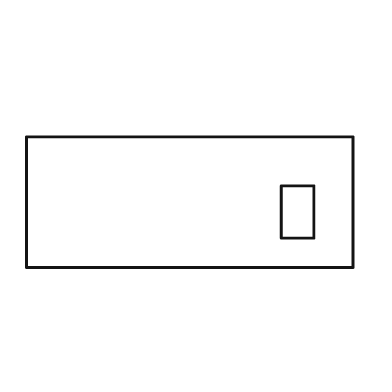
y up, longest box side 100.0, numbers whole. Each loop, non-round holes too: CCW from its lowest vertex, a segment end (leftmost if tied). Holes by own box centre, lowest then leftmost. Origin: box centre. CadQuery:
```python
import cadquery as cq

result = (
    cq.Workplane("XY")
    .moveTo(-50.0, -20.0)
    .lineTo(50.0, -20.0)
    .lineTo(50.0, 20.0)
    .lineTo(-50.0, 20.0)
    .close()
    .moveTo(28.0, -11.0)
    .lineTo(38.0, -11.0)
    .lineTo(38.0, 5.0)
    .lineTo(28.0, 5.0)
    .close()
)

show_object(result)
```